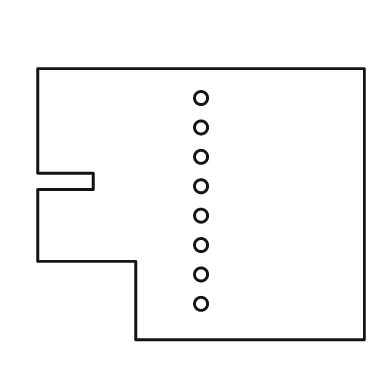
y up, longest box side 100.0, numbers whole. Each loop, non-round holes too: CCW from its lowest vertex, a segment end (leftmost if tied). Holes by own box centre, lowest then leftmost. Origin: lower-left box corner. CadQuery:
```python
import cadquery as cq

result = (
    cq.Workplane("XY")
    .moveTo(30.0, 0.0)
    .lineTo(100.0, 0.0)
    .lineTo(100.0, 83.0)
    .lineTo(0.0, 83.0)
    .lineTo(0.0, 51.0)
    .lineTo(17.0, 51.0)
    .lineTo(17.0, 46.0)
    .lineTo(0.0, 46.0)
    .lineTo(0.0, 24.0)
    .lineTo(30.0, 24.0)
    .close()
    .moveTo(50.0, 11.0)
    .circle(2.0)
    .moveTo(50.0, 20.0)
    .circle(2.0)
    .moveTo(50.0, 29.0)
    .circle(2.0)
    .moveTo(50.0, 38.0)
    .circle(2.0)
    .moveTo(50.0, 47.0)
    .circle(2.0)
    .moveTo(50.0, 56.0)
    .circle(2.0)
    .moveTo(50.0, 65.0)
    .circle(2.0)
    .moveTo(50.0, 74.0)
    .circle(2.0)
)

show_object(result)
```